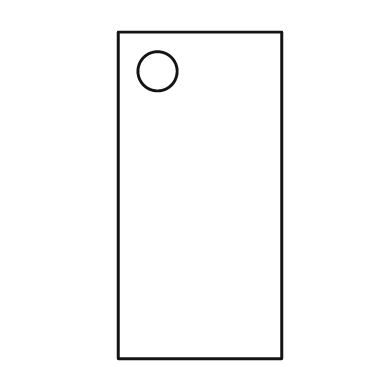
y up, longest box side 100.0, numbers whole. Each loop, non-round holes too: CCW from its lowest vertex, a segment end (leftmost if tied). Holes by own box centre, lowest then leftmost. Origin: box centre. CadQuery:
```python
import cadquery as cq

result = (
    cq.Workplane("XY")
    .moveTo(-25.0, -50.0)
    .lineTo(25.0, -50.0)
    .lineTo(25.0, 50.0)
    .lineTo(-25.0, 50.0)
    .close()
    .moveTo(-13.0, 38.0)
    .circle(6.0)
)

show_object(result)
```